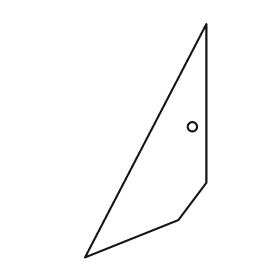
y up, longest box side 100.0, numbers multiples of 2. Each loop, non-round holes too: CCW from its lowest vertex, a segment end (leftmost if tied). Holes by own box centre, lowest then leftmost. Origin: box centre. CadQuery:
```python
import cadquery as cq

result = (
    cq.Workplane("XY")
    .moveTo(-26.0, -50.0)
    .lineTo(14.0, -34.0)
    .lineTo(26.0, -18.0)
    .lineTo(26.0, 50.0)
    .close()
    .moveTo(20.0, 6.0)
    .circle(2.0)
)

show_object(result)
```